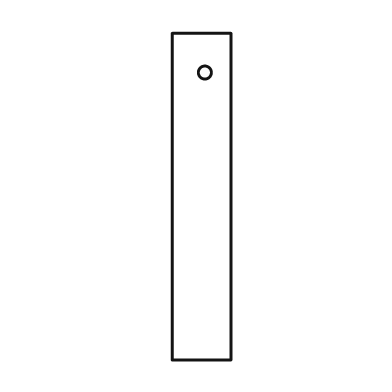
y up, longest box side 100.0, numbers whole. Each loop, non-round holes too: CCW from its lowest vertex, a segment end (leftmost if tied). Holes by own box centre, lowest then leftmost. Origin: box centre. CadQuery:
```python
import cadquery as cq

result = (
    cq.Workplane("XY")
    .moveTo(-9.0, -50.0)
    .lineTo(9.0, -50.0)
    .lineTo(9.0, 50.0)
    .lineTo(-9.0, 50.0)
    .close()
    .moveTo(1.0, 38.0)
    .circle(2.0)
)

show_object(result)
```